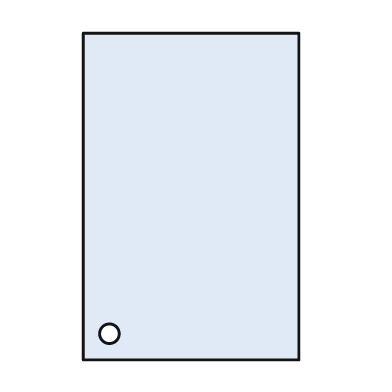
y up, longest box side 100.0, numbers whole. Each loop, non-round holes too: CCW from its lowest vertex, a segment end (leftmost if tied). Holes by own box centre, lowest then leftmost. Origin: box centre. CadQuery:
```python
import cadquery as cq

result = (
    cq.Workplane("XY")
    .moveTo(-33.0, -50.0)
    .lineTo(33.0, -50.0)
    .lineTo(33.0, 50.0)
    .lineTo(-33.0, 50.0)
    .close()
    .moveTo(-25.0, -42.0)
    .circle(3.0)
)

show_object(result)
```